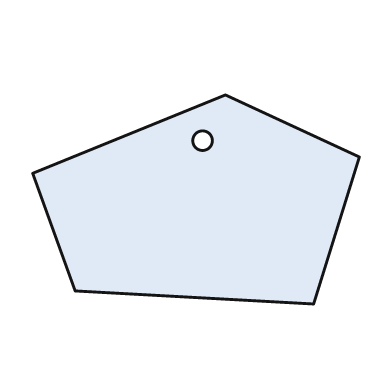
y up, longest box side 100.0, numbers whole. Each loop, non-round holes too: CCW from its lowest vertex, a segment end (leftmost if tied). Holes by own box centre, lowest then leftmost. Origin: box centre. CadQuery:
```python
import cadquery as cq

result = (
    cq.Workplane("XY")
    .moveTo(36.0, -32.0)
    .lineTo(50.0, 13.0)
    .lineTo(9.0, 32.0)
    .lineTo(-50.0, 8.0)
    .lineTo(-37.0, -28.0)
    .close()
    .moveTo(2.0, 18.0)
    .circle(3.0)
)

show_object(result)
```